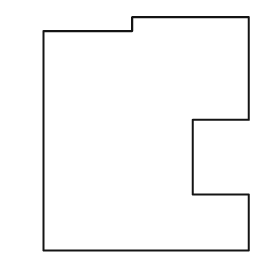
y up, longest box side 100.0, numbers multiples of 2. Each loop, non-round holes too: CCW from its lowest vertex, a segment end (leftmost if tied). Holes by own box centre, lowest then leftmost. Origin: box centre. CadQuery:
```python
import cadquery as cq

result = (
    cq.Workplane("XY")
    .moveTo(-44.0, -50.0)
    .lineTo(44.0, -50.0)
    .lineTo(44.0, -26.0)
    .lineTo(20.0, -26.0)
    .lineTo(20.0, 6.0)
    .lineTo(44.0, 6.0)
    .lineTo(44.0, 50.0)
    .lineTo(-6.0, 50.0)
    .lineTo(-6.0, 44.0)
    .lineTo(-44.0, 44.0)
    .close()
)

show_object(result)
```